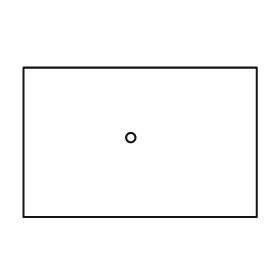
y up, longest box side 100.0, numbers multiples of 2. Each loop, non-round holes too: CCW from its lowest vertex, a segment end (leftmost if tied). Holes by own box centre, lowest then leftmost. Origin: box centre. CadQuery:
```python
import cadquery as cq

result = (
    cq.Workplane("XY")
    .moveTo(-50.0, -32.0)
    .lineTo(50.0, -32.0)
    .lineTo(50.0, 32.0)
    .lineTo(-50.0, 32.0)
    .close()
    .moveTo(-4.0, 2.0)
    .circle(2.0)
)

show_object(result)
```